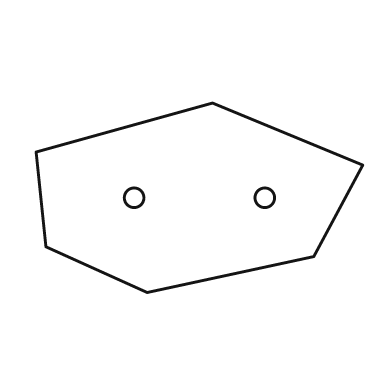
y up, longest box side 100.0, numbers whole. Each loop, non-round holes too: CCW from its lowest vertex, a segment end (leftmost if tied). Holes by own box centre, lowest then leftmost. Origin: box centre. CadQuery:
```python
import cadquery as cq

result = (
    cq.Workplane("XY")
    .moveTo(-16.0, -29.0)
    .lineTo(35.0, -18.0)
    .lineTo(50.0, 10.0)
    .lineTo(4.0, 29.0)
    .lineTo(-50.0, 14.0)
    .lineTo(-47.0, -15.0)
    .close()
    .moveTo(-20.0, 0.0)
    .circle(3.0)
    .moveTo(20.0, 0.0)
    .circle(3.0)
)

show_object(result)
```